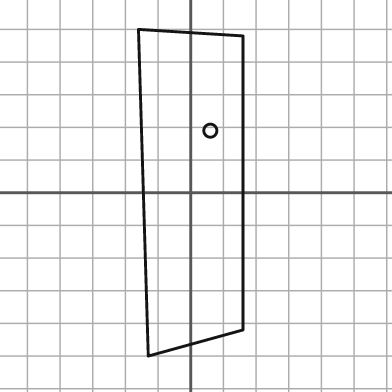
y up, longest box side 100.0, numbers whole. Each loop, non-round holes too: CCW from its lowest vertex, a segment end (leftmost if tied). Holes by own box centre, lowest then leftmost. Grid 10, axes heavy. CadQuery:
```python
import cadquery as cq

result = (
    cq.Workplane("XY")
    .moveTo(-13.0, -50.0)
    .lineTo(16.0, -42.0)
    .lineTo(16.0, 48.0)
    .lineTo(-16.0, 50.0)
    .close()
    .moveTo(6.0, 19.0)
    .circle(2.0)
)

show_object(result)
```